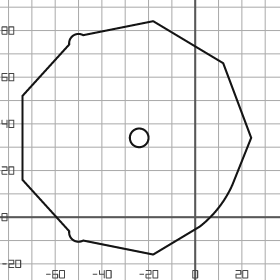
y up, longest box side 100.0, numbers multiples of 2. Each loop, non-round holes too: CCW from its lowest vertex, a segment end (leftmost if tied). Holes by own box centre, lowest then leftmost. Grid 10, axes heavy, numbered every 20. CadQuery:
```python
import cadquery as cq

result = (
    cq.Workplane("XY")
    .moveTo(-18.0, -16.0)
    .lineTo(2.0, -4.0)
    .threePointArc((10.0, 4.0), (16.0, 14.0))
    .lineTo(24.0, 34.0)
    .lineTo(12.0, 66.0)
    .lineTo(-18.0, 84.0)
    .lineTo(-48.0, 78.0)
    .threePointArc((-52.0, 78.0), (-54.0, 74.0))
    .lineTo(-74.0, 52.0)
    .lineTo(-74.0, 16.0)
    .lineTo(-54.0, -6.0)
    .threePointArc((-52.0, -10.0), (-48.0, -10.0))
    .close()
    .moveTo(-24.0, 34.0)
    .circle(4.0)
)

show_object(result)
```